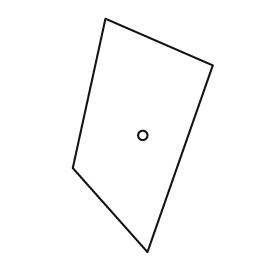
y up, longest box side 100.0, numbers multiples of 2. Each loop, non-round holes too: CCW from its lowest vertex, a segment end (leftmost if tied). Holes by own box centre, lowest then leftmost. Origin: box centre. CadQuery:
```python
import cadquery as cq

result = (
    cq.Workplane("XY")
    .moveTo(2.0, -50.0)
    .lineTo(30.0, 30.0)
    .lineTo(-16.0, 50.0)
    .lineTo(-30.0, -14.0)
    .close()
    .moveTo(0.0, 0.0)
    .circle(2.0)
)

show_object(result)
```